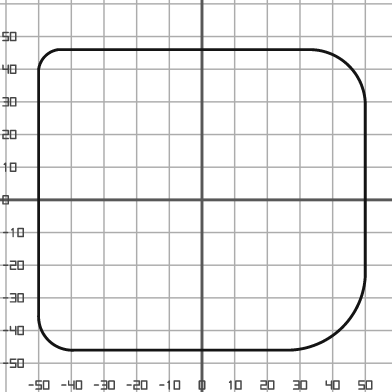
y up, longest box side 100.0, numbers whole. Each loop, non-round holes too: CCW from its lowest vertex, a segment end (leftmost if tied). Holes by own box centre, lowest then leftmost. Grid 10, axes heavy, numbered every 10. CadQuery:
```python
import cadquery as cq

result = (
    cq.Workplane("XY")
    .moveTo(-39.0, -46.0)
    .lineTo(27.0, -46.0)
    .threePointArc((43.0, -39.0), (50.0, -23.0))
    .lineTo(50.0, 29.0)
    .threePointArc((45.0, 41.0), (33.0, 46.0))
    .lineTo(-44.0, 46.0)
    .threePointArc((-48.0, 44.0), (-50.0, 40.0))
    .lineTo(-50.0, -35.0)
    .threePointArc((-47.0, -43.0), (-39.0, -46.0))
    .close()
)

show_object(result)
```